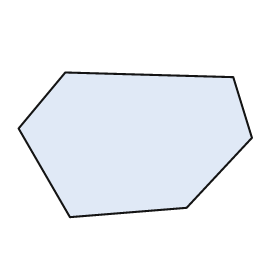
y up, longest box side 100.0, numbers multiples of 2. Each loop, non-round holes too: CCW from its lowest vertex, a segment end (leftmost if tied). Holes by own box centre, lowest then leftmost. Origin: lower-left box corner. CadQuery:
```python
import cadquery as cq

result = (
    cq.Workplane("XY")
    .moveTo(22.0, 0.0)
    .lineTo(72.0, 4.0)
    .lineTo(100.0, 34.0)
    .lineTo(92.0, 60.0)
    .lineTo(20.0, 62.0)
    .lineTo(0.0, 38.0)
    .close()
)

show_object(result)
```